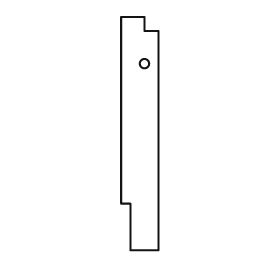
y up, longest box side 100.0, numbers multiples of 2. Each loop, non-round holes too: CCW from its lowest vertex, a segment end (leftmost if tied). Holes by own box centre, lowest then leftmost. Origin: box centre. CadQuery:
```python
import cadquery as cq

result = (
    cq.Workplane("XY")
    .moveTo(-4.0, -50.0)
    .lineTo(8.0, -50.0)
    .lineTo(8.0, 44.0)
    .lineTo(2.0, 44.0)
    .lineTo(2.0, 50.0)
    .lineTo(-8.0, 50.0)
    .lineTo(-8.0, -30.0)
    .lineTo(-4.0, -30.0)
    .close()
    .moveTo(2.0, 30.0)
    .circle(2.0)
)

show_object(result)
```